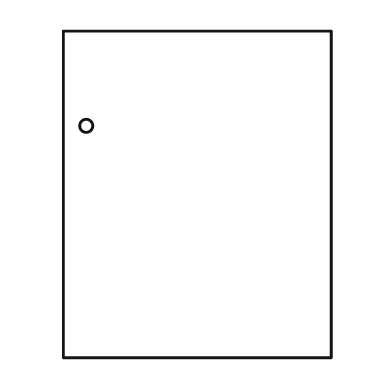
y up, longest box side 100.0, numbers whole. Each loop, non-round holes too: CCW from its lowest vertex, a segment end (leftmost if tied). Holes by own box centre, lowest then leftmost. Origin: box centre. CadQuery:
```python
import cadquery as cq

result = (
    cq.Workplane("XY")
    .moveTo(-41.0, -50.0)
    .lineTo(41.0, -50.0)
    .lineTo(41.0, 50.0)
    .lineTo(-41.0, 50.0)
    .close()
    .moveTo(-34.0, 21.0)
    .circle(2.0)
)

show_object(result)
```